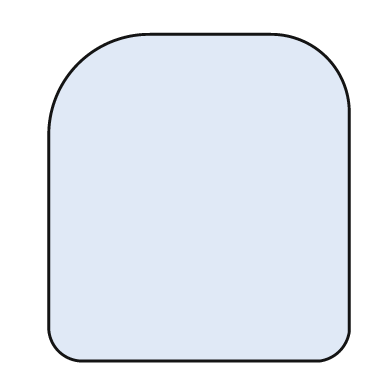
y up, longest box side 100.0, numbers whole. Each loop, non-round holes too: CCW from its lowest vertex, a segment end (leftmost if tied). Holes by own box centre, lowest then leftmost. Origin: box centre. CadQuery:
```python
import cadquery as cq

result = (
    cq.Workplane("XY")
    .moveTo(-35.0, -50.0)
    .lineTo(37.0, -50.0)
    .threePointArc((43.0, -47.0), (46.0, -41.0))
    .lineTo(46.0, 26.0)
    .threePointArc((39.0, 43.0), (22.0, 50.0))
    .lineTo(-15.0, 50.0)
    .threePointArc((-37.0, 41.0), (-46.0, 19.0))
    .lineTo(-46.0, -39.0)
    .threePointArc((-43.0, -47.0), (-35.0, -50.0))
    .close()
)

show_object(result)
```